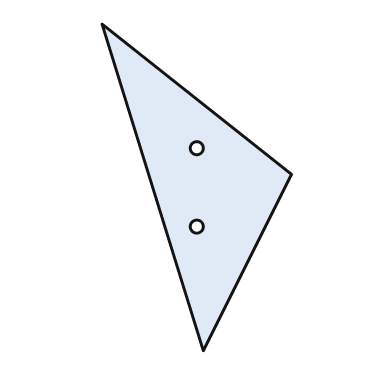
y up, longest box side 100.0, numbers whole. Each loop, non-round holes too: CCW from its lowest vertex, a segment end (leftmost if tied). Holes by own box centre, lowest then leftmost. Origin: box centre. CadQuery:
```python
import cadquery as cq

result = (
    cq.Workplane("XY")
    .moveTo(2.0, -50.0)
    .lineTo(29.0, 4.0)
    .lineTo(-29.0, 50.0)
    .close()
    .moveTo(0.0, -12.0)
    .circle(2.0)
    .moveTo(0.0, 12.0)
    .circle(2.0)
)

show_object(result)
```